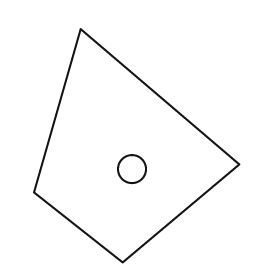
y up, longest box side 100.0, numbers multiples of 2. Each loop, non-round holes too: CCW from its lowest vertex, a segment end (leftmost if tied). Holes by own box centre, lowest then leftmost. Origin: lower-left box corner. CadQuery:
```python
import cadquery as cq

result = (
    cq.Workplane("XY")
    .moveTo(38.0, 0.0)
    .lineTo(88.0, 42.0)
    .lineTo(20.0, 100.0)
    .lineTo(0.0, 30.0)
    .close()
    .moveTo(42.0, 40.0)
    .circle(6.0)
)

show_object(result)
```